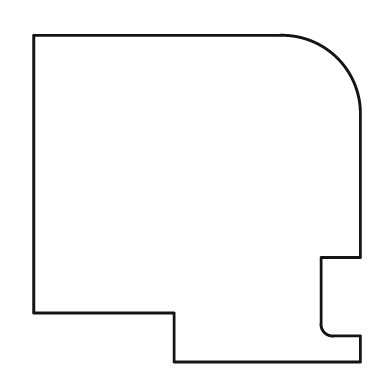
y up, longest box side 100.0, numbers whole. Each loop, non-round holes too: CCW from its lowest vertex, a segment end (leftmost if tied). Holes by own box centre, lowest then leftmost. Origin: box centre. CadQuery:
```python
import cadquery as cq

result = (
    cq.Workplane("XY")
    .moveTo(-7.0, -50.0)
    .lineTo(50.0, -50.0)
    .lineTo(50.0, -42.0)
    .lineTo(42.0, -42.0)
    .threePointArc((39.0, -41.0), (38.0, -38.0))
    .lineTo(38.0, -18.0)
    .lineTo(50.0, -18.0)
    .lineTo(50.0, 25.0)
    .threePointArc((43.0, 43.0), (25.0, 50.0))
    .lineTo(-50.0, 50.0)
    .lineTo(-50.0, -35.0)
    .lineTo(-7.0, -35.0)
    .close()
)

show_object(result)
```